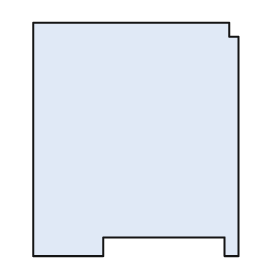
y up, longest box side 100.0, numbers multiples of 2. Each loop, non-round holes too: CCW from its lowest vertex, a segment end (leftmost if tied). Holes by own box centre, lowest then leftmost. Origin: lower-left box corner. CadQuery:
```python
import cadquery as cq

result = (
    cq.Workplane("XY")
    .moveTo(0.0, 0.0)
    .lineTo(30.0, 0.0)
    .lineTo(30.0, 8.0)
    .lineTo(82.0, 8.0)
    .lineTo(82.0, 0.0)
    .lineTo(88.0, 0.0)
    .lineTo(88.0, 94.0)
    .lineTo(84.0, 94.0)
    .lineTo(84.0, 100.0)
    .lineTo(0.0, 100.0)
    .close()
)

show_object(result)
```